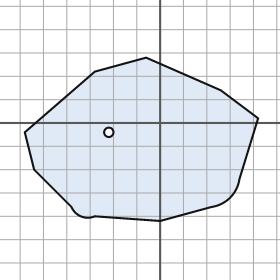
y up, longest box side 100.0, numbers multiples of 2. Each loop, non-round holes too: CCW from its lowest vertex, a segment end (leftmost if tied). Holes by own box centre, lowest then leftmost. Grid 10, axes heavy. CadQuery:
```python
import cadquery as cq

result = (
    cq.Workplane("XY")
    .moveTo(0.0, -42.0)
    .lineTo(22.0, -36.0)
    .threePointArc((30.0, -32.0), (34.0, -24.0))
    .lineTo(42.0, 2.0)
    .lineTo(26.0, 14.0)
    .lineTo(-6.0, 28.0)
    .lineTo(-28.0, 22.0)
    .lineTo(-58.0, -4.0)
    .lineTo(-54.0, -20.0)
    .lineTo(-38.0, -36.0)
    .threePointArc((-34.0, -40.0), (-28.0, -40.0))
    .close()
    .moveTo(-22.0, -4.0)
    .circle(2.0)
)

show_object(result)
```